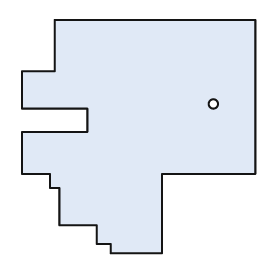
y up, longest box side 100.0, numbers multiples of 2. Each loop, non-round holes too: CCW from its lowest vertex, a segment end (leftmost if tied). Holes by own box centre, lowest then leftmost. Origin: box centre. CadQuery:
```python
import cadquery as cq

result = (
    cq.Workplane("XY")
    .moveTo(-12.0, -50.0)
    .lineTo(10.0, -50.0)
    .lineTo(10.0, -16.0)
    .lineTo(50.0, -16.0)
    .lineTo(50.0, 50.0)
    .lineTo(-36.0, 50.0)
    .lineTo(-36.0, 28.0)
    .lineTo(-50.0, 28.0)
    .lineTo(-50.0, 12.0)
    .lineTo(-22.0, 12.0)
    .lineTo(-22.0, 2.0)
    .lineTo(-50.0, 2.0)
    .lineTo(-50.0, -16.0)
    .lineTo(-38.0, -16.0)
    .lineTo(-38.0, -22.0)
    .lineTo(-34.0, -22.0)
    .lineTo(-34.0, -38.0)
    .lineTo(-18.0, -38.0)
    .lineTo(-18.0, -46.0)
    .lineTo(-12.0, -46.0)
    .close()
    .moveTo(32.0, 14.0)
    .circle(2.0)
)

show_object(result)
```